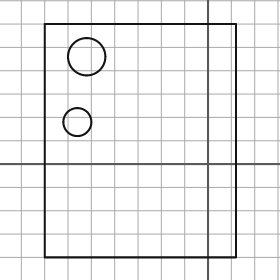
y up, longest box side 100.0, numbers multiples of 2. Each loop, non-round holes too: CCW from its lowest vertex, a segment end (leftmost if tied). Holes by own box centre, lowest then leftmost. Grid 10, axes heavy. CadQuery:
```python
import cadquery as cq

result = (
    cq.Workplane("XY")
    .moveTo(-70.0, -40.0)
    .lineTo(12.0, -40.0)
    .lineTo(12.0, 60.0)
    .lineTo(-70.0, 60.0)
    .close()
    .moveTo(-56.0, 18.0)
    .circle(6.0)
    .moveTo(-52.0, 46.0)
    .circle(8.0)
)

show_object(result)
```